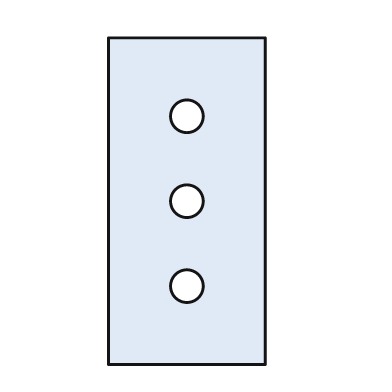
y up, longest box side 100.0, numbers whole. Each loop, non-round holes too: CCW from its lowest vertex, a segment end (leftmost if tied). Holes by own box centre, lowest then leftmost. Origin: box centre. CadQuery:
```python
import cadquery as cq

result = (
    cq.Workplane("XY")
    .moveTo(-24.0, -50.0)
    .lineTo(24.0, -50.0)
    .lineTo(24.0, 50.0)
    .lineTo(-24.0, 50.0)
    .close()
    .moveTo(0.0, -26.0)
    .circle(5.0)
    .moveTo(0.0, 0.0)
    .circle(5.0)
    .moveTo(0.0, 26.0)
    .circle(5.0)
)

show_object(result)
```